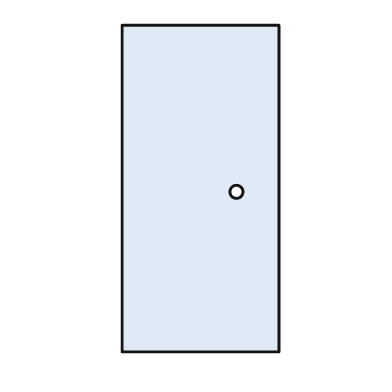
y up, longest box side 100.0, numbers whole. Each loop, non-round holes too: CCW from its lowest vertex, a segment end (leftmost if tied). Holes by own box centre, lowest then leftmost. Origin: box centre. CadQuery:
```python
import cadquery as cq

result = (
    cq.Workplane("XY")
    .moveTo(-24.0, -50.0)
    .lineTo(24.0, -50.0)
    .lineTo(24.0, 50.0)
    .lineTo(-24.0, 50.0)
    .close()
    .moveTo(11.0, -1.0)
    .circle(2.0)
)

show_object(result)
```